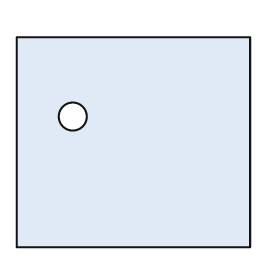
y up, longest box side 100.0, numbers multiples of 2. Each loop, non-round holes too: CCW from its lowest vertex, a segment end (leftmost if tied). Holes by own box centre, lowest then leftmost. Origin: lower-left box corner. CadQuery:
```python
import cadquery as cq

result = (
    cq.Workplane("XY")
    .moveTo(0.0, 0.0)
    .lineTo(100.0, 0.0)
    .lineTo(100.0, 90.0)
    .lineTo(0.0, 90.0)
    .close()
    .moveTo(24.0, 56.0)
    .circle(6.0)
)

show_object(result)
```